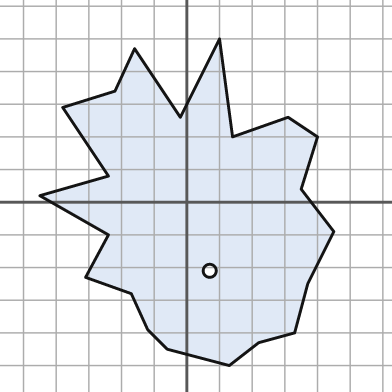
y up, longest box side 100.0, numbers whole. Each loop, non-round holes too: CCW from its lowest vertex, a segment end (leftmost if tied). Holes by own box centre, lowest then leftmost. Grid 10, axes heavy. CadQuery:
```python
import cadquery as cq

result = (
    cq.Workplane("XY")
    .moveTo(13.0, -50.0)
    .lineTo(22.0, -43.0)
    .lineTo(33.0, -40.0)
    .lineTo(37.0, -25.0)
    .lineTo(45.0, -9.0)
    .lineTo(35.0, 4.0)
    .lineTo(40.0, 20.0)
    .lineTo(31.0, 26.0)
    .lineTo(14.0, 20.0)
    .lineTo(10.0, 50.0)
    .lineTo(-2.0, 26.0)
    .lineTo(-16.0, 47.0)
    .lineTo(-22.0, 34.0)
    .lineTo(-38.0, 29.0)
    .lineTo(-24.0, 8.0)
    .lineTo(-45.0, 2.0)
    .lineTo(-24.0, -10.0)
    .lineTo(-31.0, -23.0)
    .lineTo(-17.0, -28.0)
    .lineTo(-12.0, -39.0)
    .lineTo(-6.0, -45.0)
    .close()
    .moveTo(7.0, -21.0)
    .circle(2.0)
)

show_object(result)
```